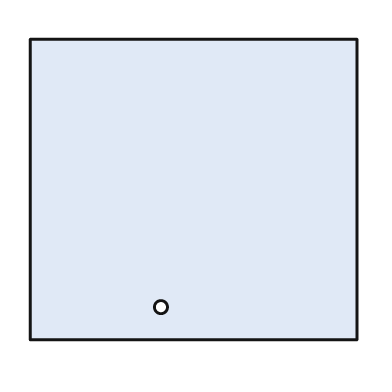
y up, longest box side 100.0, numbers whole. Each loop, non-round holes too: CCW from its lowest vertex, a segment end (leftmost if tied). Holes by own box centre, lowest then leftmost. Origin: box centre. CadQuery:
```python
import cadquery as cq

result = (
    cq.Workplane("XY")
    .moveTo(-50.0, -46.0)
    .lineTo(50.0, -46.0)
    .lineTo(50.0, 46.0)
    .lineTo(-50.0, 46.0)
    .close()
    .moveTo(-10.0, -36.0)
    .circle(2.0)
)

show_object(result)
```